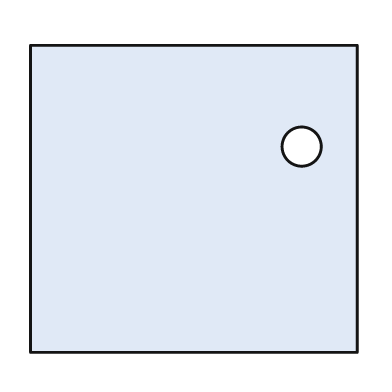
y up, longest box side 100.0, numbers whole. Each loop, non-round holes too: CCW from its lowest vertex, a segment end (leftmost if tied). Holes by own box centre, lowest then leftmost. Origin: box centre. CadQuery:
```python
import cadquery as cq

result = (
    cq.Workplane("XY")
    .moveTo(-50.0, -47.0)
    .lineTo(50.0, -47.0)
    .lineTo(50.0, 47.0)
    .lineTo(-50.0, 47.0)
    .close()
    .moveTo(33.0, 16.0)
    .circle(6.0)
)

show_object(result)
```